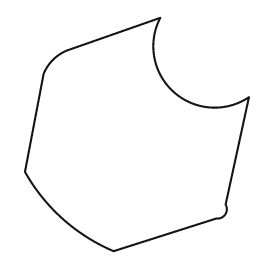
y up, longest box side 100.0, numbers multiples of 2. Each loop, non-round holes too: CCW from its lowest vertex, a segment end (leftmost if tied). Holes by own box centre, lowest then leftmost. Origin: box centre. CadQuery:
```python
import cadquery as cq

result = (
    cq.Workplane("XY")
    .moveTo(-10.0, -50.0)
    .lineTo(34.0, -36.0)
    .threePointArc((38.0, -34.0), (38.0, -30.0))
    .lineTo(48.0, 16.0)
    .threePointArc((16.0, 18.0), (10.0, 50.0))
    .lineTo(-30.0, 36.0)
    .threePointArc((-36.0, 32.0), (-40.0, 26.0))
    .lineTo(-48.0, -16.0)
    .threePointArc((-32.0, -36.0), (-10.0, -50.0))
    .close()
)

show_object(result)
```